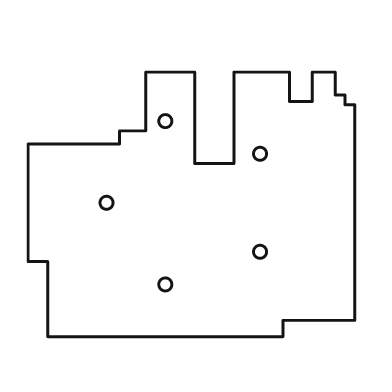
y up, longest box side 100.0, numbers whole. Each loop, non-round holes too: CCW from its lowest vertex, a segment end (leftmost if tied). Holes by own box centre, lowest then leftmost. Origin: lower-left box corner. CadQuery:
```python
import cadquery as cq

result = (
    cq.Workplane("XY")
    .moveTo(6.0, 0.0)
    .lineTo(78.0, 0.0)
    .lineTo(78.0, 5.0)
    .lineTo(100.0, 5.0)
    .lineTo(100.0, 71.0)
    .lineTo(97.0, 71.0)
    .lineTo(97.0, 74.0)
    .lineTo(94.0, 74.0)
    .lineTo(94.0, 81.0)
    .lineTo(87.0, 81.0)
    .lineTo(87.0, 72.0)
    .lineTo(80.0, 72.0)
    .lineTo(80.0, 81.0)
    .lineTo(63.0, 81.0)
    .lineTo(63.0, 53.0)
    .lineTo(51.0, 53.0)
    .lineTo(51.0, 81.0)
    .lineTo(36.0, 81.0)
    .lineTo(36.0, 63.0)
    .lineTo(28.0, 63.0)
    .lineTo(28.0, 59.0)
    .lineTo(0.0, 59.0)
    .lineTo(0.0, 23.0)
    .lineTo(6.0, 23.0)
    .close()
    .moveTo(42.0, 16.0)
    .circle(2.0)
    .moveTo(71.0, 26.0)
    .circle(2.0)
    .moveTo(24.0, 41.0)
    .circle(2.0)
    .moveTo(71.0, 56.0)
    .circle(2.0)
    .moveTo(42.0, 66.0)
    .circle(2.0)
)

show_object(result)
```